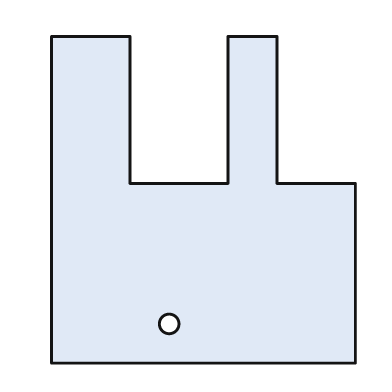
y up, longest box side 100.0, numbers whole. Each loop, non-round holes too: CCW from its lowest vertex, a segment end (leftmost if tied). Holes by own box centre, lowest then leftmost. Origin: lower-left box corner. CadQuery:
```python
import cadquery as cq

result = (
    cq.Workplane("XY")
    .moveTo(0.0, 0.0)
    .lineTo(93.0, 0.0)
    .lineTo(93.0, 55.0)
    .lineTo(69.0, 55.0)
    .lineTo(69.0, 100.0)
    .lineTo(54.0, 100.0)
    .lineTo(54.0, 55.0)
    .lineTo(24.0, 55.0)
    .lineTo(24.0, 100.0)
    .lineTo(0.0, 100.0)
    .close()
    .moveTo(36.0, 12.0)
    .circle(3.0)
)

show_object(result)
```